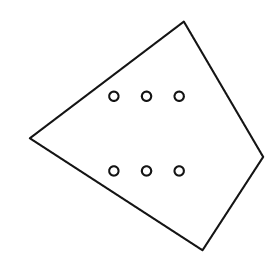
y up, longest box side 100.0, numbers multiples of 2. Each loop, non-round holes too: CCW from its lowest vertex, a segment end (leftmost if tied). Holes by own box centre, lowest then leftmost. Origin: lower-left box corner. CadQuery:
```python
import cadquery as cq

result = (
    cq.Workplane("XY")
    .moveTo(74.0, 0.0)
    .lineTo(100.0, 40.0)
    .lineTo(66.0, 98.0)
    .lineTo(0.0, 48.0)
    .close()
    .moveTo(36.0, 34.0)
    .circle(2.0)
    .moveTo(50.0, 34.0)
    .circle(2.0)
    .moveTo(64.0, 34.0)
    .circle(2.0)
    .moveTo(36.0, 66.0)
    .circle(2.0)
    .moveTo(50.0, 66.0)
    .circle(2.0)
    .moveTo(64.0, 66.0)
    .circle(2.0)
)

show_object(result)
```